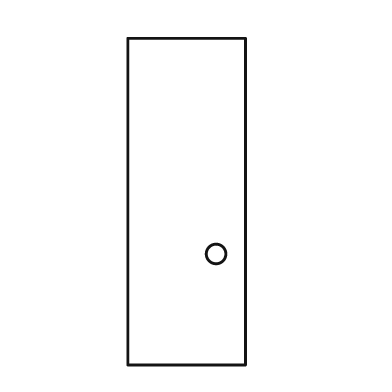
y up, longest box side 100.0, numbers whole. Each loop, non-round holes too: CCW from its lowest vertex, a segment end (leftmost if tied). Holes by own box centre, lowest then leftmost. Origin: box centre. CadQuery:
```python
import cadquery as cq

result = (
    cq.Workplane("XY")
    .moveTo(-18.0, -50.0)
    .lineTo(18.0, -50.0)
    .lineTo(18.0, 50.0)
    .lineTo(-18.0, 50.0)
    .close()
    .moveTo(9.0, -16.0)
    .circle(3.0)
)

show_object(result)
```